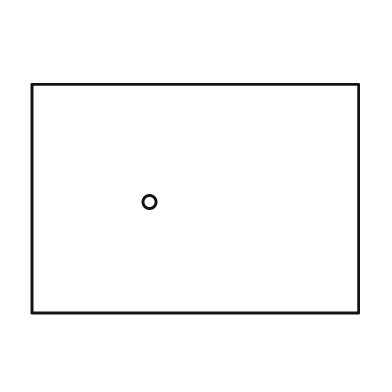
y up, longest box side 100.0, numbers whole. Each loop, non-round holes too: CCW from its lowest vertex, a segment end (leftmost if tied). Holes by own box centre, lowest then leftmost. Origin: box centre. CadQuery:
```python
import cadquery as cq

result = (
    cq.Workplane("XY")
    .moveTo(-50.0, -35.0)
    .lineTo(50.0, -35.0)
    .lineTo(50.0, 35.0)
    .lineTo(-50.0, 35.0)
    .close()
    .moveTo(-14.0, -1.0)
    .circle(2.0)
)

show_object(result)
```